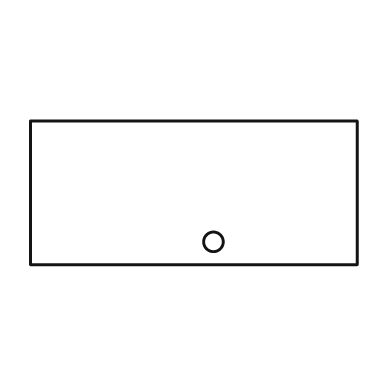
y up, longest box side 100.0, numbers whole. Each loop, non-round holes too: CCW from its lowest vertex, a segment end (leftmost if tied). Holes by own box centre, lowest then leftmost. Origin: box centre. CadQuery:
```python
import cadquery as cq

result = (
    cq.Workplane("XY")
    .moveTo(-50.0, -22.0)
    .lineTo(50.0, -22.0)
    .lineTo(50.0, 22.0)
    .lineTo(-50.0, 22.0)
    .close()
    .moveTo(6.0, -15.0)
    .circle(3.0)
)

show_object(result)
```